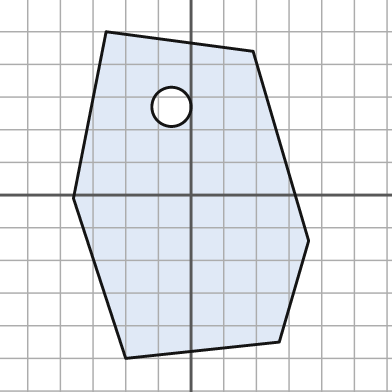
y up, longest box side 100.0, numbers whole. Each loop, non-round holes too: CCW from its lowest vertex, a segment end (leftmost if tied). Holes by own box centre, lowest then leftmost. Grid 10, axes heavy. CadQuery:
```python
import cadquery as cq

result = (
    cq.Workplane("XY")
    .moveTo(-20.0, -50.0)
    .lineTo(27.0, -45.0)
    .lineTo(36.0, -14.0)
    .lineTo(19.0, 44.0)
    .lineTo(-26.0, 50.0)
    .lineTo(-36.0, -1.0)
    .close()
    .moveTo(-6.0, 27.0)
    .circle(6.0)
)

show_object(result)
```